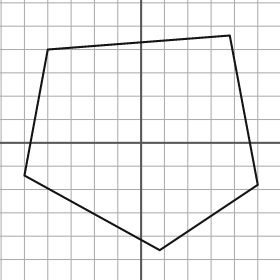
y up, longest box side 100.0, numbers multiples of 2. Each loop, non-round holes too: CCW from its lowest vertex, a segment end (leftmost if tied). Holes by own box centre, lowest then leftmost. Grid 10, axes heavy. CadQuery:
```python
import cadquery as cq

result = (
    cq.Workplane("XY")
    .moveTo(8.0, -46.0)
    .lineTo(50.0, -18.0)
    .lineTo(38.0, 46.0)
    .lineTo(-40.0, 40.0)
    .lineTo(-50.0, -14.0)
    .close()
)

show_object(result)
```